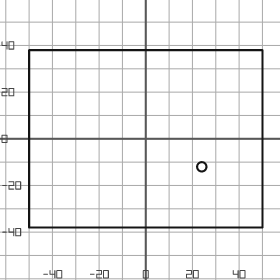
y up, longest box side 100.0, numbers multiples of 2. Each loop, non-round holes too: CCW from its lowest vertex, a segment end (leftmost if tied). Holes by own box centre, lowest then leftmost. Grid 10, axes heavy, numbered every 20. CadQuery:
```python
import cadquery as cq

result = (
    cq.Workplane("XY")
    .moveTo(-50.0, -38.0)
    .lineTo(50.0, -38.0)
    .lineTo(50.0, 38.0)
    .lineTo(-50.0, 38.0)
    .close()
    .moveTo(24.0, -12.0)
    .circle(2.0)
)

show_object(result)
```